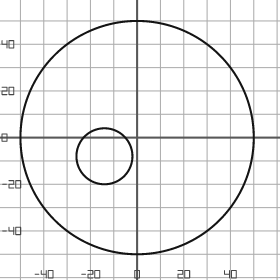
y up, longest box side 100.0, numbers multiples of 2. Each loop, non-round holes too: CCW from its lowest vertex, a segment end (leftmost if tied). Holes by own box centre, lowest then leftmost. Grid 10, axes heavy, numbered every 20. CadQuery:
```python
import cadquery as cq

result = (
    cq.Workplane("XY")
    .moveTo(0.0, 0.0)
    .circle(50.0)
    .moveTo(-14.0, -8.0)
    .circle(12.0)
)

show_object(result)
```